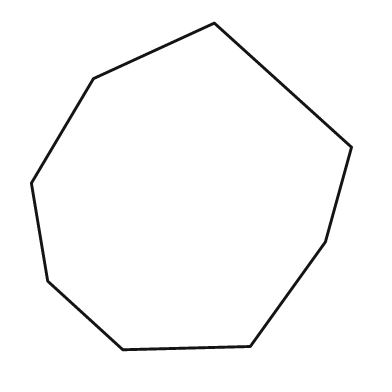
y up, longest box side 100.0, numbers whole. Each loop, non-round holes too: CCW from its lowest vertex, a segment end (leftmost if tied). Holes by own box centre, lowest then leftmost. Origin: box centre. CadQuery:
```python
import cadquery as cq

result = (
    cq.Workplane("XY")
    .moveTo(-21.0, -50.0)
    .lineTo(18.0, -49.0)
    .lineTo(41.0, -17.0)
    .lineTo(49.0, 12.0)
    .lineTo(7.0, 50.0)
    .lineTo(-30.0, 33.0)
    .lineTo(-49.0, 1.0)
    .lineTo(-44.0, -29.0)
    .close()
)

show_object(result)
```